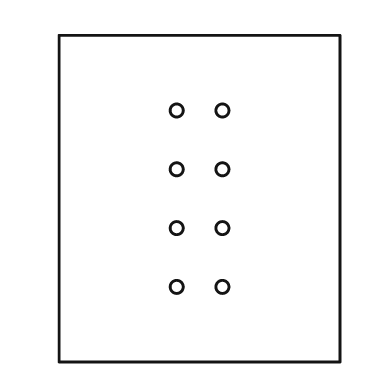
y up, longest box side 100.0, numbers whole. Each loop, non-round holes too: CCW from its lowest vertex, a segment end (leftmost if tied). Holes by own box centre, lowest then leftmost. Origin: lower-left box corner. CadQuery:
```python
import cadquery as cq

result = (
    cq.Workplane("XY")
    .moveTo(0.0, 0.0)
    .lineTo(86.0, 0.0)
    .lineTo(86.0, 100.0)
    .lineTo(0.0, 100.0)
    .close()
    .moveTo(36.0, 23.0)
    .circle(2.0)
    .moveTo(50.0, 23.0)
    .circle(2.0)
    .moveTo(36.0, 41.0)
    .circle(2.0)
    .moveTo(50.0, 41.0)
    .circle(2.0)
    .moveTo(36.0, 59.0)
    .circle(2.0)
    .moveTo(50.0, 59.0)
    .circle(2.0)
    .moveTo(36.0, 77.0)
    .circle(2.0)
    .moveTo(50.0, 77.0)
    .circle(2.0)
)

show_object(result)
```